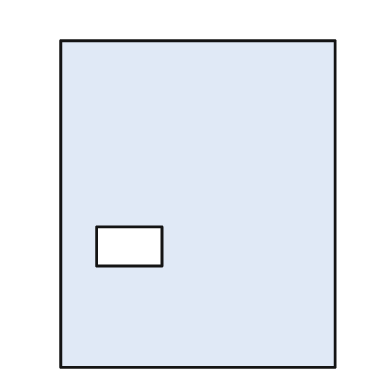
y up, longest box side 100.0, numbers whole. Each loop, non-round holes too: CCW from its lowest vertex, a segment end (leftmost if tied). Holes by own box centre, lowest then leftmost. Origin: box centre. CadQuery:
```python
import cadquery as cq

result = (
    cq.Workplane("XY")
    .moveTo(-42.0, -50.0)
    .lineTo(42.0, -50.0)
    .lineTo(42.0, 50.0)
    .lineTo(-42.0, 50.0)
    .close()
    .moveTo(-31.0, -19.0)
    .lineTo(-11.0, -19.0)
    .lineTo(-11.0, -7.0)
    .lineTo(-31.0, -7.0)
    .close()
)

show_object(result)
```